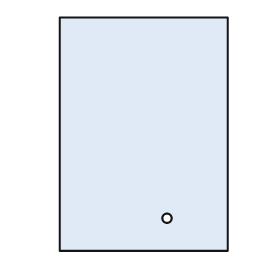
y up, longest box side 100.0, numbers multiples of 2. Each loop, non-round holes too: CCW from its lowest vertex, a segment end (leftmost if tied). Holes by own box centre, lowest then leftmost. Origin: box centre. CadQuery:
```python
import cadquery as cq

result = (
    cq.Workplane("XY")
    .moveTo(-36.0, -50.0)
    .lineTo(36.0, -50.0)
    .lineTo(36.0, 50.0)
    .lineTo(-36.0, 50.0)
    .close()
    .moveTo(10.0, -36.0)
    .circle(2.0)
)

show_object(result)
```